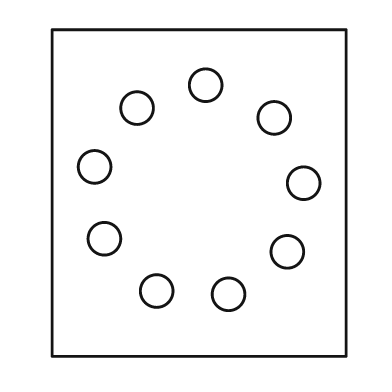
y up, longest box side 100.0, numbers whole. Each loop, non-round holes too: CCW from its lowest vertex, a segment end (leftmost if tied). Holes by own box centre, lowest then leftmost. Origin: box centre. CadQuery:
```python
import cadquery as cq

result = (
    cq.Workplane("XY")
    .moveTo(-45.0, -50.0)
    .lineTo(45.0, -50.0)
    .lineTo(45.0, 50.0)
    .lineTo(-45.0, 50.0)
    .close()
    .moveTo(9.0, -31.0)
    .circle(5.0)
    .moveTo(-13.0, -30.0)
    .circle(5.0)
    .moveTo(27.0, -18.0)
    .circle(5.0)
    .moveTo(-29.0, -14.0)
    .circle(5.0)
    .moveTo(32.0, 3.0)
    .circle(5.0)
    .moveTo(-32.0, 8.0)
    .circle(5.0)
    .moveTo(23.0, 23.0)
    .circle(5.0)
    .moveTo(-19.0, 26.0)
    .circle(5.0)
    .moveTo(2.0, 33.0)
    .circle(5.0)
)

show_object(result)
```